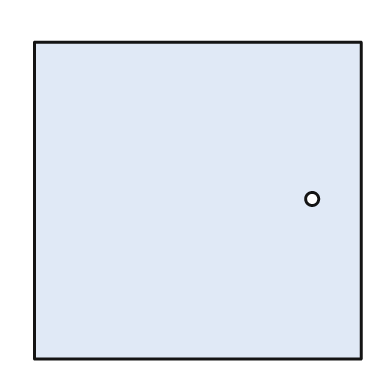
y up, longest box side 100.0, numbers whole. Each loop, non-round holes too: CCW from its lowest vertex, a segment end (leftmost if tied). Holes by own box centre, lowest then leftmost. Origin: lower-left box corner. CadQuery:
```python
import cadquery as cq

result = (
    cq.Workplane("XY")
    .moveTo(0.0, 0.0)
    .lineTo(100.0, 0.0)
    .lineTo(100.0, 97.0)
    .lineTo(0.0, 97.0)
    .close()
    .moveTo(85.0, 49.0)
    .circle(2.0)
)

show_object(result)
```